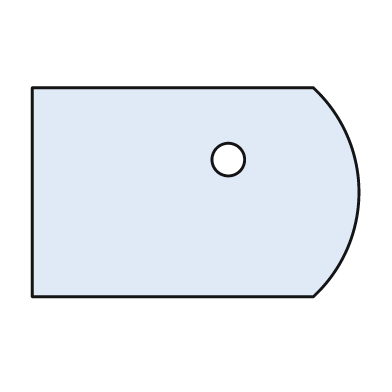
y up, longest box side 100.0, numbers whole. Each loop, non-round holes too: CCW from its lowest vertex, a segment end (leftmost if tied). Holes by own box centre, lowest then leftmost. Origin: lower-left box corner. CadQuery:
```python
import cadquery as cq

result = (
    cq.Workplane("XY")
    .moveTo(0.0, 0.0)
    .lineTo(86.0, 0.0)
    .threePointArc((100.0, 32.0), (86.0, 64.0))
    .lineTo(0.0, 64.0)
    .close()
    .moveTo(60.0, 42.0)
    .circle(5.0)
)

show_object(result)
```